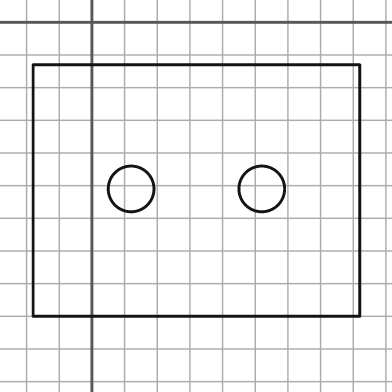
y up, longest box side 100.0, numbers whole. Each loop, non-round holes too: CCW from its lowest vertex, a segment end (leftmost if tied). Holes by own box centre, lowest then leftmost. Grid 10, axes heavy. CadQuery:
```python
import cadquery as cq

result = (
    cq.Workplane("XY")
    .moveTo(-18.0, -90.0)
    .lineTo(82.0, -90.0)
    .lineTo(82.0, -13.0)
    .lineTo(-18.0, -13.0)
    .close()
    .moveTo(12.0, -51.0)
    .circle(7.0)
    .moveTo(52.0, -51.0)
    .circle(7.0)
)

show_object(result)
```